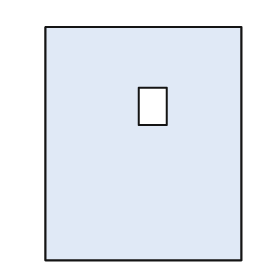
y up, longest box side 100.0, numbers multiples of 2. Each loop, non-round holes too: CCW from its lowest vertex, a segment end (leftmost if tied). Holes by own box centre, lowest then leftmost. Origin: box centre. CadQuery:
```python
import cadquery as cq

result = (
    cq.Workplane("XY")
    .moveTo(-42.0, -50.0)
    .lineTo(42.0, -50.0)
    .lineTo(42.0, 50.0)
    .lineTo(-42.0, 50.0)
    .close()
    .moveTo(-2.0, 8.0)
    .lineTo(10.0, 8.0)
    .lineTo(10.0, 24.0)
    .lineTo(-2.0, 24.0)
    .close()
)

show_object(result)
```